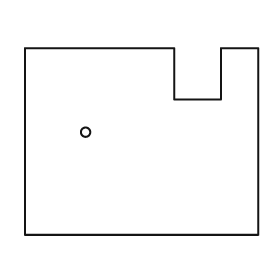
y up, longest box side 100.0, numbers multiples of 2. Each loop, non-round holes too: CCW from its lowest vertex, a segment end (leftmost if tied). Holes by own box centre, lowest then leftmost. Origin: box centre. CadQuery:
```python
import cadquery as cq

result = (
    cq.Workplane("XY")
    .moveTo(-50.0, -40.0)
    .lineTo(50.0, -40.0)
    .lineTo(50.0, 40.0)
    .lineTo(34.0, 40.0)
    .lineTo(34.0, 18.0)
    .lineTo(14.0, 18.0)
    .lineTo(14.0, 40.0)
    .lineTo(-50.0, 40.0)
    .close()
    .moveTo(-24.0, 4.0)
    .circle(2.0)
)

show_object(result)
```